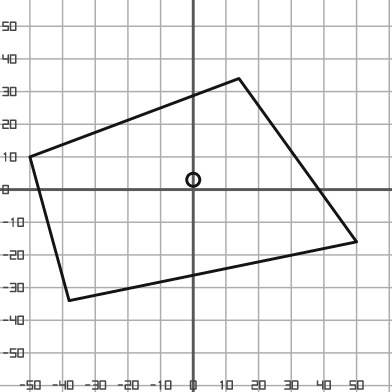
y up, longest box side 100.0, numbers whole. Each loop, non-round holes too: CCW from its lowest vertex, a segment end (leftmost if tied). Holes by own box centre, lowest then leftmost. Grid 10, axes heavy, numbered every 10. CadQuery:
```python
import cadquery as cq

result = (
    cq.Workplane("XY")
    .moveTo(-38.0, -34.0)
    .lineTo(50.0, -16.0)
    .lineTo(14.0, 34.0)
    .lineTo(-50.0, 10.0)
    .close()
    .moveTo(0.0, 3.0)
    .circle(2.0)
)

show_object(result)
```